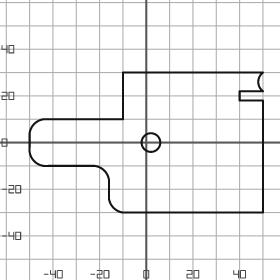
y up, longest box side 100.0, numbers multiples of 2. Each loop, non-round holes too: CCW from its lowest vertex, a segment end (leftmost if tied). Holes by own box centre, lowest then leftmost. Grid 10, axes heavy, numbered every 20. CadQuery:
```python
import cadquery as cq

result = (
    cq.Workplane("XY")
    .moveTo(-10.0, -30.0)
    .lineTo(50.0, -30.0)
    .lineTo(50.0, 18.0)
    .lineTo(40.0, 18.0)
    .lineTo(40.0, 22.0)
    .lineTo(50.0, 22.0)
    .threePointArc((48.0, 26.0), (50.0, 30.0))
    .lineTo(-10.0, 30.0)
    .lineTo(-10.0, 10.0)
    .lineTo(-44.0, 10.0)
    .threePointArc((-48.0, 8.0), (-50.0, 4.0))
    .lineTo(-50.0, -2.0)
    .threePointArc((-48.0, -8.0), (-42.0, -10.0))
    .lineTo(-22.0, -10.0)
    .threePointArc((-18.0, -12.0), (-16.0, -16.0))
    .lineTo(-16.0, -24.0)
    .threePointArc((-14.0, -28.0), (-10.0, -30.0))
    .close()
    .moveTo(2.0, 0.0)
    .circle(4.0)
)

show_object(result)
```